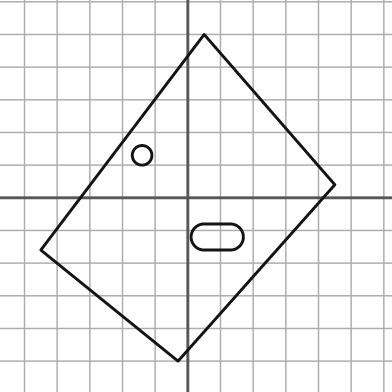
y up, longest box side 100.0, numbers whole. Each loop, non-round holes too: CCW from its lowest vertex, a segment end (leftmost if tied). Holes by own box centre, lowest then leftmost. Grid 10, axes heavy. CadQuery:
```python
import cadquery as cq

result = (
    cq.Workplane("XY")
    .moveTo(-3.0, -50.0)
    .lineTo(45.0, 4.0)
    .lineTo(5.0, 50.0)
    .lineTo(-45.0, -16.0)
    .close()
    .moveTo(5.0, -16.0)
    .lineTo(13.0, -16.0)
    .threePointArc((17.0, -12.0), (13.0, -8.0))
    .lineTo(5.0, -8.0)
    .threePointArc((1.0, -12.0), (5.0, -16.0))
    .close()
    .moveTo(-14.0, 13.0)
    .circle(3.0)
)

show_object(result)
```